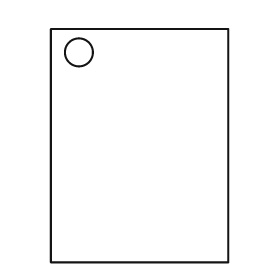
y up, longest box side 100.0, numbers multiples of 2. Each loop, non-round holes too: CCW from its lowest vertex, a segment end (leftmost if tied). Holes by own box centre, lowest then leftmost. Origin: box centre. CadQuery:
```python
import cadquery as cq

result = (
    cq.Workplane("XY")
    .moveTo(-38.0, -50.0)
    .lineTo(38.0, -50.0)
    .lineTo(38.0, 50.0)
    .lineTo(-38.0, 50.0)
    .close()
    .moveTo(-26.0, 40.0)
    .circle(6.0)
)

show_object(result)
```